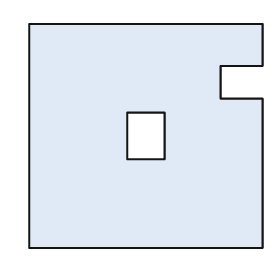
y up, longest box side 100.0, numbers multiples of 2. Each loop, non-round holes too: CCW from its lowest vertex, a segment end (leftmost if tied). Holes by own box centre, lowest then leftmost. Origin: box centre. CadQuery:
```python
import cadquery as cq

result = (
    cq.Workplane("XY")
    .moveTo(-50.0, -48.0)
    .lineTo(50.0, -48.0)
    .lineTo(50.0, 16.0)
    .lineTo(32.0, 16.0)
    .lineTo(32.0, 30.0)
    .lineTo(50.0, 30.0)
    .lineTo(50.0, 48.0)
    .lineTo(-50.0, 48.0)
    .close()
    .moveTo(-8.0, -10.0)
    .lineTo(8.0, -10.0)
    .lineTo(8.0, 10.0)
    .lineTo(-8.0, 10.0)
    .close()
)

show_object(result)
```